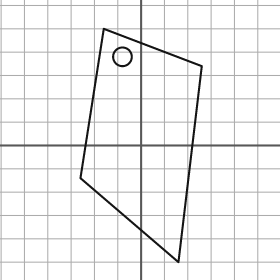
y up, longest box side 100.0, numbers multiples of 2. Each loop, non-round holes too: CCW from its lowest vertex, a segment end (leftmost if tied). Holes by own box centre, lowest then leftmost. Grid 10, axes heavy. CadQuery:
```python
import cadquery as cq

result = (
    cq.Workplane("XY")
    .moveTo(16.0, -50.0)
    .lineTo(26.0, 34.0)
    .lineTo(-16.0, 50.0)
    .lineTo(-26.0, -14.0)
    .close()
    .moveTo(-8.0, 38.0)
    .circle(4.0)
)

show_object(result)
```